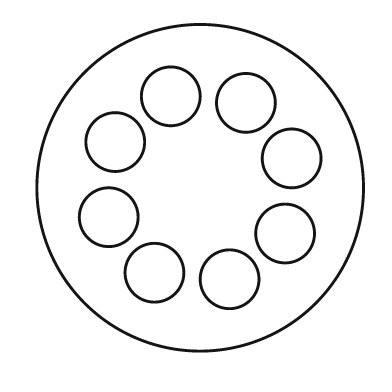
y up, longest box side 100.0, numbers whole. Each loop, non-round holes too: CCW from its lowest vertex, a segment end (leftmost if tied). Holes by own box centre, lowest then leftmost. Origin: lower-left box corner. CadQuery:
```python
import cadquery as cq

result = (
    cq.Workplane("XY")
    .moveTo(50.0, 50.0)
    .circle(50.0)
    .moveTo(59.0, 22.0)
    .circle(9.0)
    .moveTo(36.0, 24.0)
    .circle(9.0)
    .moveTo(76.0, 36.0)
    .circle(9.0)
    .moveTo(22.0, 41.0)
    .circle(9.0)
    .moveTo(78.0, 59.0)
    .circle(9.0)
    .moveTo(24.0, 64.0)
    .circle(9.0)
    .moveTo(64.0, 76.0)
    .circle(9.0)
    .moveTo(41.0, 78.0)
    .circle(9.0)
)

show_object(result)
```